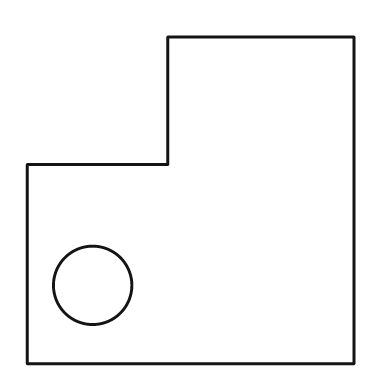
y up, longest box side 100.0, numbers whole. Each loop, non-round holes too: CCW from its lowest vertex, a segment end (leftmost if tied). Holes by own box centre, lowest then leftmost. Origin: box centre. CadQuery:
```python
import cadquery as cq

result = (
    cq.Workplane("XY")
    .moveTo(-50.0, -50.0)
    .lineTo(50.0, -50.0)
    .lineTo(50.0, 50.0)
    .lineTo(-7.0, 50.0)
    .lineTo(-7.0, 11.0)
    .lineTo(-50.0, 11.0)
    .close()
    .moveTo(-30.0, -26.0)
    .circle(12.0)
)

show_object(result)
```